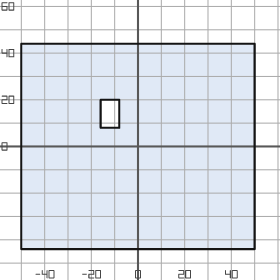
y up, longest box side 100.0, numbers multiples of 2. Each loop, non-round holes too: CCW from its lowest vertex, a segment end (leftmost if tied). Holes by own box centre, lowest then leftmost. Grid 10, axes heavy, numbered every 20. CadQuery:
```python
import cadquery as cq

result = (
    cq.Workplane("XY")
    .moveTo(-50.0, -44.0)
    .lineTo(50.0, -44.0)
    .lineTo(50.0, 44.0)
    .lineTo(-50.0, 44.0)
    .close()
    .moveTo(-16.0, 8.0)
    .lineTo(-8.0, 8.0)
    .lineTo(-8.0, 20.0)
    .lineTo(-16.0, 20.0)
    .close()
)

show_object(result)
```